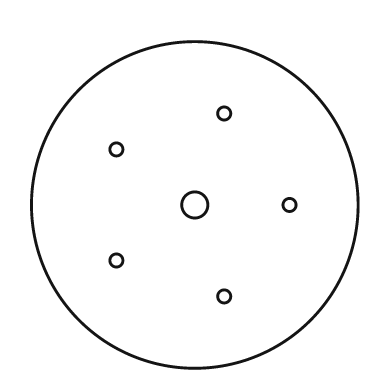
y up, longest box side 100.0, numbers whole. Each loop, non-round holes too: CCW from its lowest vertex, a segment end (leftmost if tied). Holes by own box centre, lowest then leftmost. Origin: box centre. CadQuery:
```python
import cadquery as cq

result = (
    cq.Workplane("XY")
    .moveTo(0.0, 0.0)
    .circle(50.0)
    .moveTo(9.0, -28.0)
    .circle(2.0)
    .moveTo(-24.0, -17.0)
    .circle(2.0)
    .moveTo(0.0, 0.0)
    .circle(4.0)
    .moveTo(29.0, 0.0)
    .circle(2.0)
    .moveTo(-24.0, 17.0)
    .circle(2.0)
    .moveTo(9.0, 28.0)
    .circle(2.0)
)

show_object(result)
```